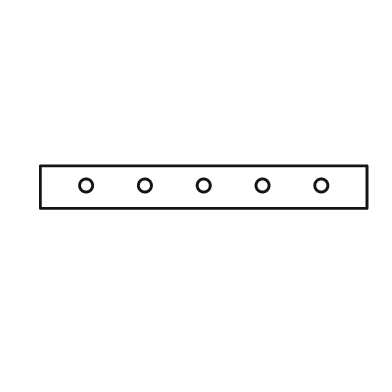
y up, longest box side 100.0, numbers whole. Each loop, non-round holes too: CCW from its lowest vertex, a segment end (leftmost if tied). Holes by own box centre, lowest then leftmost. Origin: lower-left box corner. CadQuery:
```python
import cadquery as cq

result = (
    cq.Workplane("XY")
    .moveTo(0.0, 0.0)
    .lineTo(100.0, 0.0)
    .lineTo(100.0, 13.0)
    .lineTo(0.0, 13.0)
    .close()
    .moveTo(14.0, 7.0)
    .circle(2.0)
    .moveTo(32.0, 7.0)
    .circle(2.0)
    .moveTo(50.0, 7.0)
    .circle(2.0)
    .moveTo(68.0, 7.0)
    .circle(2.0)
    .moveTo(86.0, 7.0)
    .circle(2.0)
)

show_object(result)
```